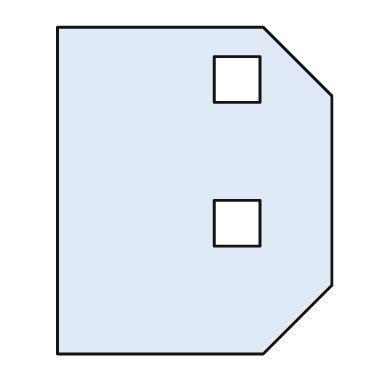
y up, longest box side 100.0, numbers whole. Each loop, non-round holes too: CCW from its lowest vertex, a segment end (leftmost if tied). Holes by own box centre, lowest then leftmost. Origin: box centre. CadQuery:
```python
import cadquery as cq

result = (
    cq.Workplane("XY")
    .moveTo(-42.0, -50.0)
    .lineTo(21.0, -50.0)
    .lineTo(42.0, -29.0)
    .lineTo(42.0, 29.0)
    .lineTo(21.0, 50.0)
    .lineTo(-42.0, 50.0)
    .close()
    .moveTo(6.0, -17.0)
    .lineTo(20.0, -17.0)
    .lineTo(20.0, -3.0)
    .lineTo(6.0, -3.0)
    .close()
    .moveTo(6.0, 27.0)
    .lineTo(20.0, 27.0)
    .lineTo(20.0, 41.0)
    .lineTo(6.0, 41.0)
    .close()
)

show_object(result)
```